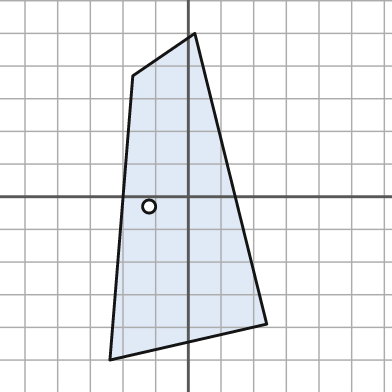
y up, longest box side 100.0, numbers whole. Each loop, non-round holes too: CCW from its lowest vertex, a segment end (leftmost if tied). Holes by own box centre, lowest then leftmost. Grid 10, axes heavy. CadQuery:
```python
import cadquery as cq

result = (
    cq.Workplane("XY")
    .moveTo(-24.0, -50.0)
    .lineTo(24.0, -39.0)
    .lineTo(2.0, 50.0)
    .lineTo(-17.0, 37.0)
    .close()
    .moveTo(-12.0, -3.0)
    .circle(2.0)
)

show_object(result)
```